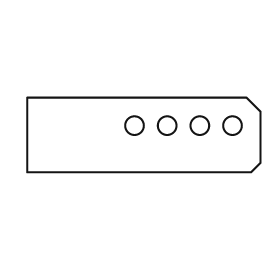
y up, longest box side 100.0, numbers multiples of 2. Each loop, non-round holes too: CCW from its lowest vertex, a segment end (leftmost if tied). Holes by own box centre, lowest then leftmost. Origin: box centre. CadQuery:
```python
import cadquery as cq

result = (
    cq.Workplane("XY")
    .moveTo(-50.0, -16.0)
    .lineTo(46.0, -16.0)
    .lineTo(50.0, -12.0)
    .lineTo(50.0, 10.0)
    .lineTo(44.0, 16.0)
    .lineTo(-50.0, 16.0)
    .close()
    .moveTo(-4.0, 4.0)
    .circle(4.0)
    .moveTo(10.0, 4.0)
    .circle(4.0)
    .moveTo(24.0, 4.0)
    .circle(4.0)
    .moveTo(38.0, 4.0)
    .circle(4.0)
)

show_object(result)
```